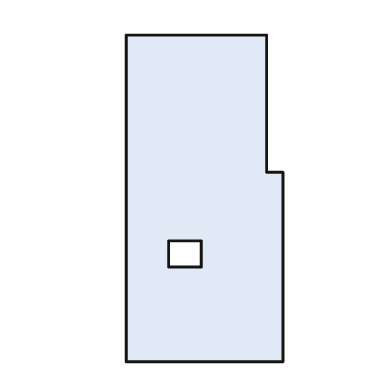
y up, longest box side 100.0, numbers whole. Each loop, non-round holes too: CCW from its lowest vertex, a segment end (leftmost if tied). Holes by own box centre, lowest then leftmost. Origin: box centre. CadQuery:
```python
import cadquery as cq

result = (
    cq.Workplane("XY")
    .moveTo(-24.0, -50.0)
    .lineTo(24.0, -50.0)
    .lineTo(24.0, 8.0)
    .lineTo(19.0, 8.0)
    .lineTo(19.0, 50.0)
    .lineTo(-24.0, 50.0)
    .close()
    .moveTo(-11.0, -21.0)
    .lineTo(-1.0, -21.0)
    .lineTo(-1.0, -13.0)
    .lineTo(-11.0, -13.0)
    .close()
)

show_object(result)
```